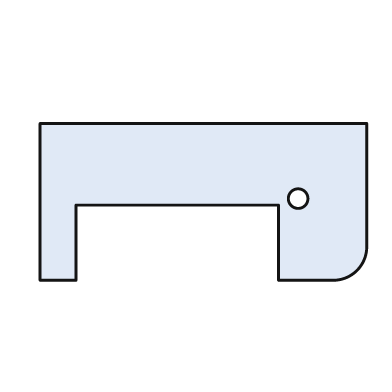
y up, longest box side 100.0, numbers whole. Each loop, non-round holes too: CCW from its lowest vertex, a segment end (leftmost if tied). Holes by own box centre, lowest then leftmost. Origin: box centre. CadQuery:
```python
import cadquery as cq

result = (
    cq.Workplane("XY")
    .moveTo(-50.0, -24.0)
    .lineTo(-39.0, -24.0)
    .lineTo(-39.0, -1.0)
    .lineTo(23.0, -1.0)
    .lineTo(23.0, -24.0)
    .lineTo(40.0, -24.0)
    .threePointArc((47.0, -21.0), (50.0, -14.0))
    .lineTo(50.0, 24.0)
    .lineTo(-50.0, 24.0)
    .close()
    .moveTo(29.0, 1.0)
    .circle(3.0)
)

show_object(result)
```